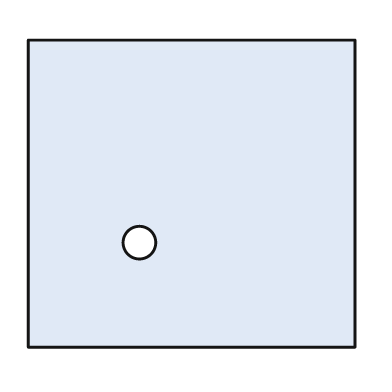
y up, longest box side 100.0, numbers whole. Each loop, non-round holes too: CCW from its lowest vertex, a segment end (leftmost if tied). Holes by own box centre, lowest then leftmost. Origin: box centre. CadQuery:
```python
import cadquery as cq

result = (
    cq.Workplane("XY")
    .moveTo(-50.0, -47.0)
    .lineTo(50.0, -47.0)
    .lineTo(50.0, 47.0)
    .lineTo(-50.0, 47.0)
    .close()
    .moveTo(-16.0, -15.0)
    .circle(5.0)
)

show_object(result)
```